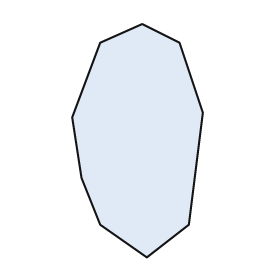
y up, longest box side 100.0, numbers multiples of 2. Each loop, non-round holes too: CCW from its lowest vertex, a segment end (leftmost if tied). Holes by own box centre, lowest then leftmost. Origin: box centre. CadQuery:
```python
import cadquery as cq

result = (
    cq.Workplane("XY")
    .moveTo(4.0, -50.0)
    .lineTo(22.0, -36.0)
    .lineTo(28.0, 12.0)
    .lineTo(18.0, 42.0)
    .lineTo(2.0, 50.0)
    .lineTo(-16.0, 42.0)
    .lineTo(-28.0, 10.0)
    .lineTo(-24.0, -16.0)
    .lineTo(-16.0, -36.0)
    .close()
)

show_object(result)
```